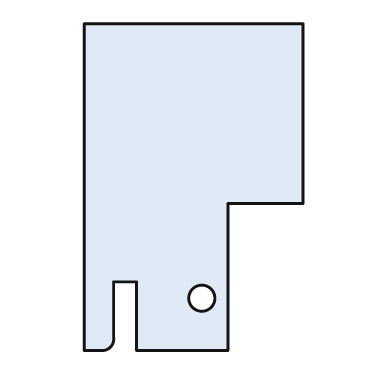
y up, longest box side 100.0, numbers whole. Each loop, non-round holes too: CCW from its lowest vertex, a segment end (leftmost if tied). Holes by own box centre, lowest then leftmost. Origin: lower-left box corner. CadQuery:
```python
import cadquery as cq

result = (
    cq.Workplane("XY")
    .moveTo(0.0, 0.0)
    .lineTo(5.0, 0.0)
    .threePointArc((8.0, 1.0), (9.0, 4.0))
    .lineTo(9.0, 21.0)
    .lineTo(16.0, 21.0)
    .lineTo(16.0, 0.0)
    .lineTo(44.0, 0.0)
    .lineTo(44.0, 45.0)
    .lineTo(67.0, 45.0)
    .lineTo(67.0, 100.0)
    .lineTo(0.0, 100.0)
    .close()
    .moveTo(36.0, 16.0)
    .circle(4.0)
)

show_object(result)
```